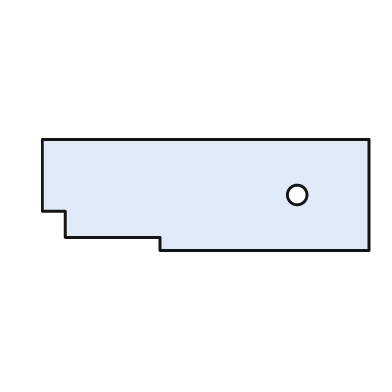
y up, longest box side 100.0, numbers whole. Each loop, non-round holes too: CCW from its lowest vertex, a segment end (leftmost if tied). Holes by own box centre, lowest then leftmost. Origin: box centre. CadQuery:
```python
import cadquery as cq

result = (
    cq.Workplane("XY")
    .moveTo(-14.0, -17.0)
    .lineTo(50.0, -17.0)
    .lineTo(50.0, 17.0)
    .lineTo(-50.0, 17.0)
    .lineTo(-50.0, -5.0)
    .lineTo(-43.0, -5.0)
    .lineTo(-43.0, -13.0)
    .lineTo(-14.0, -13.0)
    .close()
    .moveTo(28.0, 0.0)
    .circle(3.0)
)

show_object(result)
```